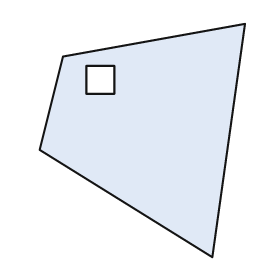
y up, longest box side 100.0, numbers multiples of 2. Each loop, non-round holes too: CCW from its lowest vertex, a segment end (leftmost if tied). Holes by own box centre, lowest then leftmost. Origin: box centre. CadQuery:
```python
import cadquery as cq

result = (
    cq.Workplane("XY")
    .moveTo(30.0, -50.0)
    .lineTo(44.0, 50.0)
    .lineTo(-34.0, 36.0)
    .lineTo(-44.0, -4.0)
    .close()
    .moveTo(-24.0, 20.0)
    .lineTo(-12.0, 20.0)
    .lineTo(-12.0, 32.0)
    .lineTo(-24.0, 32.0)
    .close()
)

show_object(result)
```